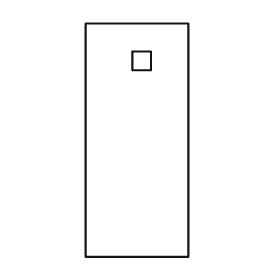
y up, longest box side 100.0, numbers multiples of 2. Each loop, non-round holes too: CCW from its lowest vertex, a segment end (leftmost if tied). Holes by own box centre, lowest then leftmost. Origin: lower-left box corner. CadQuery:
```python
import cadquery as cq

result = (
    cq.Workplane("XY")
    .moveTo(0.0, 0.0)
    .lineTo(44.0, 0.0)
    .lineTo(44.0, 100.0)
    .lineTo(0.0, 100.0)
    .close()
    .moveTo(20.0, 80.0)
    .lineTo(28.0, 80.0)
    .lineTo(28.0, 88.0)
    .lineTo(20.0, 88.0)
    .close()
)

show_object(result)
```